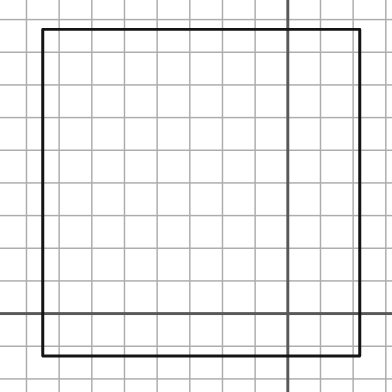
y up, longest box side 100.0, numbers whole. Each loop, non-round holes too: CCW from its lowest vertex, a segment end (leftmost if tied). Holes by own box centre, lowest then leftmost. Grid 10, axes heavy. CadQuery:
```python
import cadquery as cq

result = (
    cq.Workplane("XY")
    .moveTo(-75.0, -13.0)
    .lineTo(22.0, -13.0)
    .lineTo(22.0, 87.0)
    .lineTo(-75.0, 87.0)
    .close()
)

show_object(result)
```